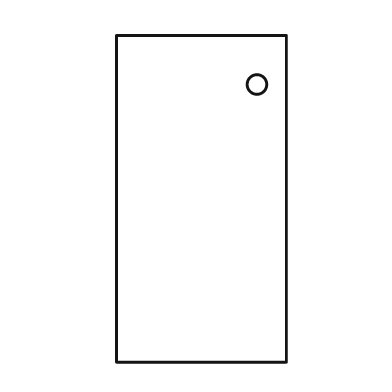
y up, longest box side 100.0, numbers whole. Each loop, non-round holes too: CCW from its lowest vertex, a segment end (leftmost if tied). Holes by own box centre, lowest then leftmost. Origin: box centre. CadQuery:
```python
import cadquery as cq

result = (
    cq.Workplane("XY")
    .moveTo(-26.0, -50.0)
    .lineTo(26.0, -50.0)
    .lineTo(26.0, 50.0)
    .lineTo(-26.0, 50.0)
    .close()
    .moveTo(17.0, 35.0)
    .circle(3.0)
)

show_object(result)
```